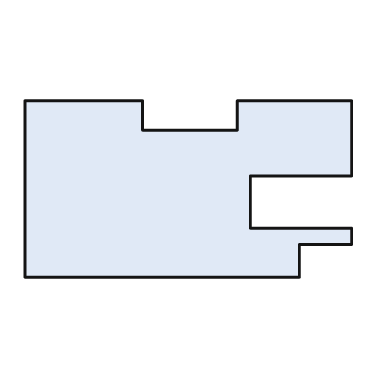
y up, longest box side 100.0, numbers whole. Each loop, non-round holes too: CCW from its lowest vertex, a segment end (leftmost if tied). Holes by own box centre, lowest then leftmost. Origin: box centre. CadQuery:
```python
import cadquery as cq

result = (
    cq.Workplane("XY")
    .moveTo(-50.0, -27.0)
    .lineTo(34.0, -27.0)
    .lineTo(34.0, -17.0)
    .lineTo(50.0, -17.0)
    .lineTo(50.0, -12.0)
    .lineTo(19.0, -12.0)
    .lineTo(19.0, 4.0)
    .lineTo(50.0, 4.0)
    .lineTo(50.0, 27.0)
    .lineTo(15.0, 27.0)
    .lineTo(15.0, 18.0)
    .lineTo(-14.0, 18.0)
    .lineTo(-14.0, 27.0)
    .lineTo(-50.0, 27.0)
    .close()
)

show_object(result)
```